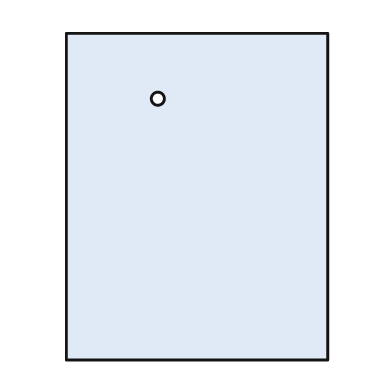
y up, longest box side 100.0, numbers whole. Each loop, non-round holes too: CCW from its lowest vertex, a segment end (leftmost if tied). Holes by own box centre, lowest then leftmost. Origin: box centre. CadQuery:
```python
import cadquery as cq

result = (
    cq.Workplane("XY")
    .moveTo(-40.0, -50.0)
    .lineTo(40.0, -50.0)
    .lineTo(40.0, 50.0)
    .lineTo(-40.0, 50.0)
    .close()
    .moveTo(-12.0, 30.0)
    .circle(2.0)
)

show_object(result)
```